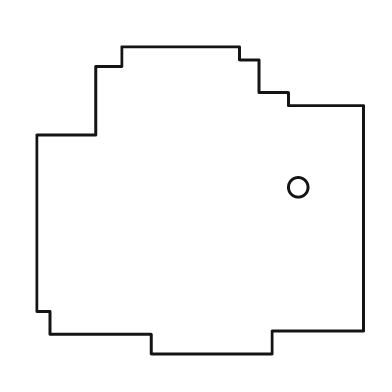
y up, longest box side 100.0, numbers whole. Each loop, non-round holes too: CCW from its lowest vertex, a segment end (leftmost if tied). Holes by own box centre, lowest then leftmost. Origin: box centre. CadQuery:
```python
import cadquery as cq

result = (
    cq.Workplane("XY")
    .moveTo(-15.0, -47.0)
    .lineTo(22.0, -47.0)
    .lineTo(22.0, -40.0)
    .lineTo(50.0, -40.0)
    .lineTo(50.0, 29.0)
    .lineTo(27.0, 29.0)
    .lineTo(27.0, 33.0)
    .lineTo(18.0, 33.0)
    .lineTo(18.0, 43.0)
    .lineTo(12.0, 43.0)
    .lineTo(12.0, 47.0)
    .lineTo(-24.0, 47.0)
    .lineTo(-24.0, 41.0)
    .lineTo(-32.0, 41.0)
    .lineTo(-32.0, 20.0)
    .lineTo(-50.0, 20.0)
    .lineTo(-50.0, -34.0)
    .lineTo(-46.0, -34.0)
    .lineTo(-46.0, -41.0)
    .lineTo(-15.0, -41.0)
    .close()
    .moveTo(30.0, 4.0)
    .circle(3.0)
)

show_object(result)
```